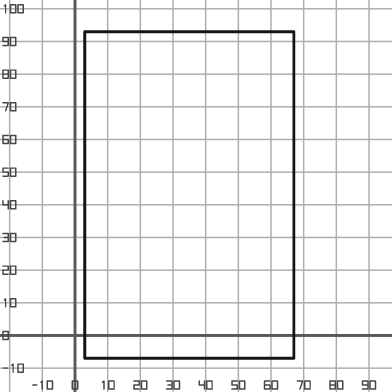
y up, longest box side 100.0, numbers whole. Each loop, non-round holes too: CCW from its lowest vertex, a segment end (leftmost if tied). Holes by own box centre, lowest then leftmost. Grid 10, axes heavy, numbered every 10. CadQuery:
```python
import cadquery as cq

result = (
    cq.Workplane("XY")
    .moveTo(3.0, -7.0)
    .lineTo(67.0, -7.0)
    .lineTo(67.0, 93.0)
    .lineTo(3.0, 93.0)
    .close()
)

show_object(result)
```